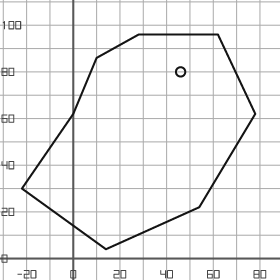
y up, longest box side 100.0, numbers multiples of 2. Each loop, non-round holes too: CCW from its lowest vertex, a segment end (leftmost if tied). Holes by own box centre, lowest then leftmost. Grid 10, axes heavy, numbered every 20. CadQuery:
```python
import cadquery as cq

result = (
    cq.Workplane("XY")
    .moveTo(14.0, 4.0)
    .lineTo(54.0, 22.0)
    .lineTo(78.0, 62.0)
    .lineTo(62.0, 96.0)
    .lineTo(28.0, 96.0)
    .lineTo(10.0, 86.0)
    .lineTo(0.0, 62.0)
    .lineTo(-22.0, 30.0)
    .close()
    .moveTo(46.0, 80.0)
    .circle(2.0)
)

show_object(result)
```